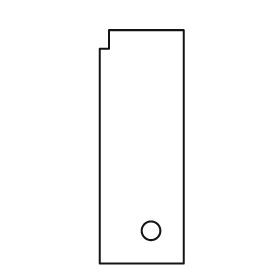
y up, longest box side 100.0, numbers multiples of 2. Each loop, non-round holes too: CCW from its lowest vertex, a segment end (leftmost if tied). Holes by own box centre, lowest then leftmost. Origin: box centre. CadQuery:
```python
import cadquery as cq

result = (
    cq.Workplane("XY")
    .moveTo(-18.0, -50.0)
    .lineTo(18.0, -50.0)
    .lineTo(18.0, 50.0)
    .lineTo(-14.0, 50.0)
    .lineTo(-14.0, 42.0)
    .lineTo(-18.0, 42.0)
    .close()
    .moveTo(4.0, -36.0)
    .circle(4.0)
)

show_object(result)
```